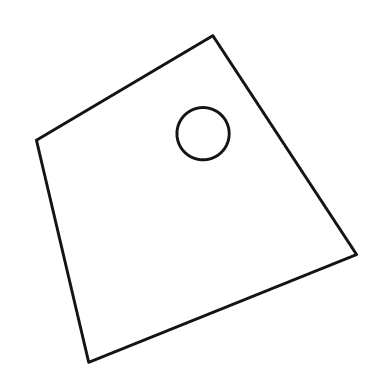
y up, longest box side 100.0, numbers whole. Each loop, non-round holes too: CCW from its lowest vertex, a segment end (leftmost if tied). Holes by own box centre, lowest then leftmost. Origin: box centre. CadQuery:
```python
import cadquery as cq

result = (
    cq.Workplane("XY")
    .moveTo(-33.0, -50.0)
    .lineTo(49.0, -17.0)
    .lineTo(5.0, 50.0)
    .lineTo(-49.0, 18.0)
    .close()
    .moveTo(2.0, 20.0)
    .circle(8.0)
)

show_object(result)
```